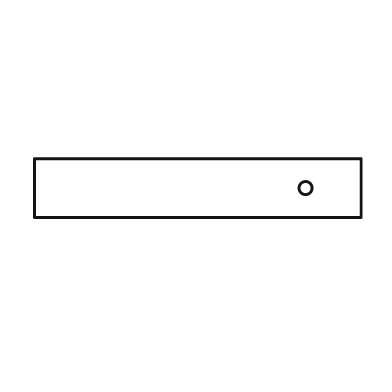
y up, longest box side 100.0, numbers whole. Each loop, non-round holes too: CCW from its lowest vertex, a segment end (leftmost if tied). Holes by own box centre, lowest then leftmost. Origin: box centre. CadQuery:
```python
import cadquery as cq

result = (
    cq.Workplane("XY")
    .moveTo(-50.0, -9.0)
    .lineTo(50.0, -9.0)
    .lineTo(50.0, 9.0)
    .lineTo(-50.0, 9.0)
    .close()
    .moveTo(33.0, 0.0)
    .circle(2.0)
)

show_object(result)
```